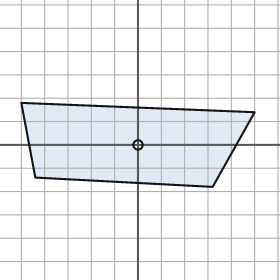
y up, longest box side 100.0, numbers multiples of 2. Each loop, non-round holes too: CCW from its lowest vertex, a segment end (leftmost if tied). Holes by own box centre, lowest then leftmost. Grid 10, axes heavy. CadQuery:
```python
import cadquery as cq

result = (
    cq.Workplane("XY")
    .moveTo(32.0, -18.0)
    .lineTo(50.0, 14.0)
    .lineTo(-50.0, 18.0)
    .lineTo(-44.0, -14.0)
    .close()
    .moveTo(0.0, 0.0)
    .circle(2.0)
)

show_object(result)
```